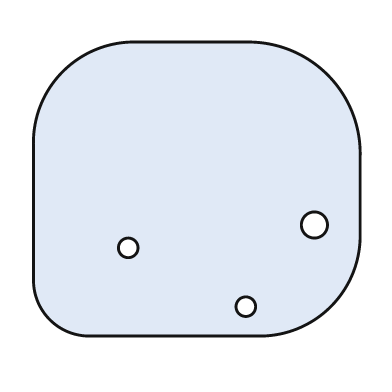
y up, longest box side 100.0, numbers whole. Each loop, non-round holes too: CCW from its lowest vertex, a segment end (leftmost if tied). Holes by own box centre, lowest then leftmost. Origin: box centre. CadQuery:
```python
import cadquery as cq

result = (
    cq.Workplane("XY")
    .moveTo(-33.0, -45.0)
    .lineTo(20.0, -45.0)
    .threePointArc((41.0, -36.0), (50.0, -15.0))
    .lineTo(50.0, 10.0)
    .threePointArc((40.0, 35.0), (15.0, 45.0))
    .lineTo(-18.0, 45.0)
    .threePointArc((-41.0, 36.0), (-50.0, 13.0))
    .lineTo(-50.0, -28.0)
    .threePointArc((-45.0, -40.0), (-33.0, -45.0))
    .close()
    .moveTo(15.0, -36.0)
    .circle(3.0)
    .moveTo(-21.0, -18.0)
    .circle(3.0)
    .moveTo(36.0, -11.0)
    .circle(4.0)
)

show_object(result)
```